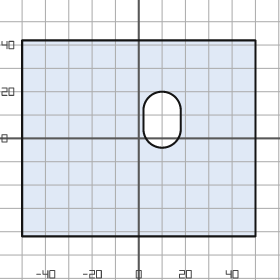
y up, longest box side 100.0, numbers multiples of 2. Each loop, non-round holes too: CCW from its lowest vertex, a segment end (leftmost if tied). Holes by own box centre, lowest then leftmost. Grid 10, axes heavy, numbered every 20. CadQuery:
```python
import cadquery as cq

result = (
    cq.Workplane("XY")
    .moveTo(-50.0, -42.0)
    .lineTo(50.0, -42.0)
    .lineTo(50.0, 42.0)
    .lineTo(-50.0, 42.0)
    .close()
    .moveTo(2.0, 4.0)
    .threePointArc((10.0, -4.0), (18.0, 4.0))
    .lineTo(18.0, 12.0)
    .threePointArc((10.0, 20.0), (2.0, 12.0))
    .close()
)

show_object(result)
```